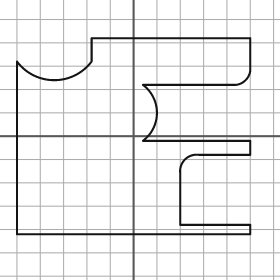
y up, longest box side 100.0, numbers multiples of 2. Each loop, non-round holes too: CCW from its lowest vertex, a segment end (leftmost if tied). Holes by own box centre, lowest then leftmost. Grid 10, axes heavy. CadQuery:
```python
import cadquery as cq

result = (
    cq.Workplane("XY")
    .moveTo(-50.0, -42.0)
    .lineTo(50.0, -42.0)
    .lineTo(50.0, -38.0)
    .lineTo(20.0, -38.0)
    .lineTo(20.0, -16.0)
    .threePointArc((22.0, -10.0), (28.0, -8.0))
    .lineTo(50.0, -8.0)
    .lineTo(50.0, -2.0)
    .lineTo(4.0, -2.0)
    .threePointArc((10.0, 10.0), (4.0, 22.0))
    .lineTo(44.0, 22.0)
    .threePointArc((48.0, 24.0), (50.0, 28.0))
    .lineTo(50.0, 42.0)
    .lineTo(-18.0, 42.0)
    .lineTo(-18.0, 32.0)
    .threePointArc((-34.0, 24.0), (-50.0, 32.0))
    .close()
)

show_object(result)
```